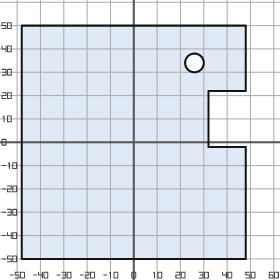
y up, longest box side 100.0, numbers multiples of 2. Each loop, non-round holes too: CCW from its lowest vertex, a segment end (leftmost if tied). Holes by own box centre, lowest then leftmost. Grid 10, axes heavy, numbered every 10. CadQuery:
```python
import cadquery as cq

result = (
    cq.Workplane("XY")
    .moveTo(-48.0, -50.0)
    .lineTo(48.0, -50.0)
    .lineTo(48.0, -2.0)
    .lineTo(32.0, -2.0)
    .lineTo(32.0, 22.0)
    .lineTo(48.0, 22.0)
    .lineTo(48.0, 50.0)
    .lineTo(-48.0, 50.0)
    .close()
    .moveTo(26.0, 34.0)
    .circle(4.0)
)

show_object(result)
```